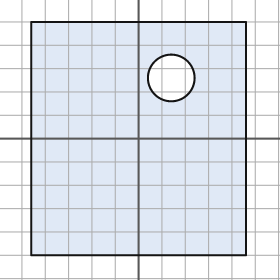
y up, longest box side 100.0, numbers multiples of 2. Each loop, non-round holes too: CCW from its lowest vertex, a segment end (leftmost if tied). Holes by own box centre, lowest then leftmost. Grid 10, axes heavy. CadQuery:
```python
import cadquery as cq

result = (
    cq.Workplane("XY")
    .moveTo(-46.0, -50.0)
    .lineTo(46.0, -50.0)
    .lineTo(46.0, 50.0)
    .lineTo(-46.0, 50.0)
    .close()
    .moveTo(14.0, 26.0)
    .circle(10.0)
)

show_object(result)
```